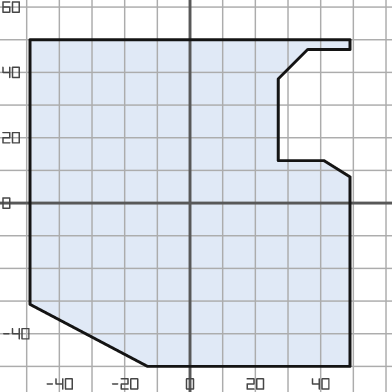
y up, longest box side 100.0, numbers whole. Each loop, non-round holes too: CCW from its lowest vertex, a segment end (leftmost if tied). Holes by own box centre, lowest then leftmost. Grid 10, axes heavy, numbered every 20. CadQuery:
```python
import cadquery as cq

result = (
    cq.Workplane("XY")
    .moveTo(-13.0, -50.0)
    .lineTo(49.0, -50.0)
    .lineTo(49.0, 8.0)
    .lineTo(41.0, 13.0)
    .lineTo(27.0, 13.0)
    .lineTo(27.0, 38.0)
    .lineTo(36.0, 47.0)
    .lineTo(49.0, 47.0)
    .lineTo(49.0, 50.0)
    .lineTo(-49.0, 50.0)
    .lineTo(-49.0, -31.0)
    .close()
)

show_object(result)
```